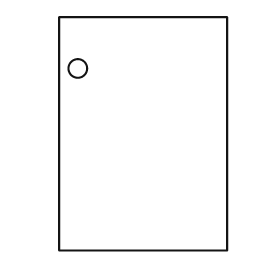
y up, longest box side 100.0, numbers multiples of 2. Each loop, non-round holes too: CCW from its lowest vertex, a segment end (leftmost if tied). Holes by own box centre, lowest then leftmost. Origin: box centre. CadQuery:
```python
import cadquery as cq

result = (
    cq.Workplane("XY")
    .moveTo(-36.0, -50.0)
    .lineTo(36.0, -50.0)
    .lineTo(36.0, 50.0)
    .lineTo(-36.0, 50.0)
    .close()
    .moveTo(-28.0, 28.0)
    .circle(4.0)
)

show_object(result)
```